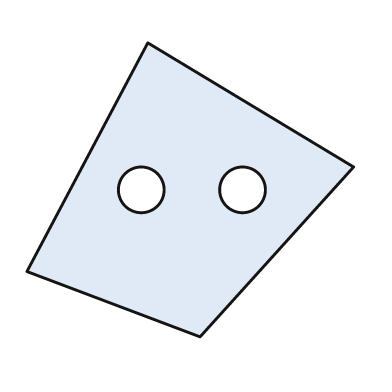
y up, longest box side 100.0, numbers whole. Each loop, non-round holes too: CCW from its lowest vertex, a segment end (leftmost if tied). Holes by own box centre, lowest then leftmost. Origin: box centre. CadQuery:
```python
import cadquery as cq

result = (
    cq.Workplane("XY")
    .moveTo(3.0, -45.0)
    .lineTo(50.0, 7.0)
    .lineTo(-13.0, 45.0)
    .lineTo(-50.0, -25.0)
    .close()
    .moveTo(-15.0, 0.0)
    .circle(7.0)
    .moveTo(16.0, 0.0)
    .circle(7.0)
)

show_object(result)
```